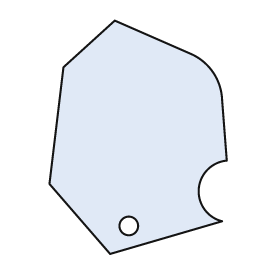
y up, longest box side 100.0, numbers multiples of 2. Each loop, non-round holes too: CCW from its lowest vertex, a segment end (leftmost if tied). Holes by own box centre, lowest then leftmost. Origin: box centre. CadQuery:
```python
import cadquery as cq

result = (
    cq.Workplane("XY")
    .moveTo(-12.0, -50.0)
    .lineTo(36.0, -36.0)
    .threePointArc((26.0, -22.0), (38.0, -10.0))
    .lineTo(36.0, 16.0)
    .threePointArc((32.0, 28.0), (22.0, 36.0))
    .lineTo(-10.0, 50.0)
    .lineTo(-32.0, 30.0)
    .lineTo(-38.0, -20.0)
    .close()
    .moveTo(-4.0, -38.0)
    .circle(4.0)
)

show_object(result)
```